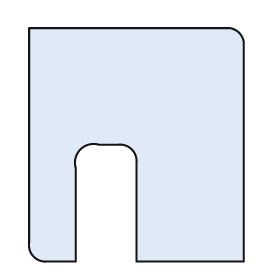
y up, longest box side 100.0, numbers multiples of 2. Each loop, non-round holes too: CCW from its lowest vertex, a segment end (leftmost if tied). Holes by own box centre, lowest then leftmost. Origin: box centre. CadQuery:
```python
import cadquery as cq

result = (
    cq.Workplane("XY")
    .moveTo(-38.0, -50.0)
    .lineTo(-26.0, -50.0)
    .lineTo(-26.0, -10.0)
    .threePointArc((-24.0, -2.0), (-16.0, 0.0))
    .lineTo(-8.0, 0.0)
    .threePointArc((-2.0, -2.0), (0.0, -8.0))
    .lineTo(0.0, -50.0)
    .lineTo(46.0, -50.0)
    .lineTo(46.0, 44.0)
    .threePointArc((44.0, 48.0), (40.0, 50.0))
    .lineTo(-46.0, 50.0)
    .lineTo(-46.0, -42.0)
    .threePointArc((-44.0, -48.0), (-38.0, -50.0))
    .close()
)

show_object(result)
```